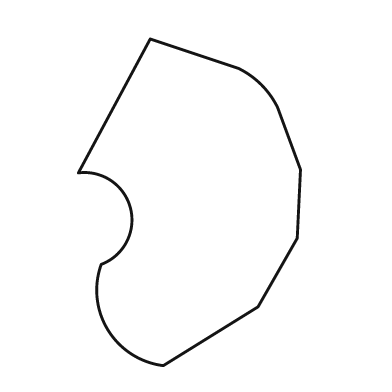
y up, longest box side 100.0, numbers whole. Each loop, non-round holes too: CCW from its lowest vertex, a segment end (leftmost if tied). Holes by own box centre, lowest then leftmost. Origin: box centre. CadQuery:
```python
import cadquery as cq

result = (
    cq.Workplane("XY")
    .moveTo(-8.0, -50.0)
    .lineTo(21.0, -32.0)
    .lineTo(33.0, -11.0)
    .lineTo(34.0, 10.0)
    .lineTo(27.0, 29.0)
    .threePointArc((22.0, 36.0), (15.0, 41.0))
    .lineTo(-12.0, 50.0)
    .lineTo(-34.0, 9.0)
    .threePointArc((-18.0, -2.0), (-27.0, -19.0))
    .threePointArc((-25.0, -39.0), (-8.0, -50.0))
    .close()
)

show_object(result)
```